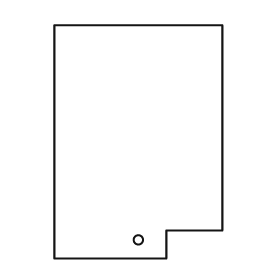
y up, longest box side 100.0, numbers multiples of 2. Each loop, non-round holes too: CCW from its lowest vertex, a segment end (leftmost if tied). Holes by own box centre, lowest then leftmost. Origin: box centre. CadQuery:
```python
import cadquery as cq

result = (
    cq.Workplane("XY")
    .moveTo(-36.0, -50.0)
    .lineTo(12.0, -50.0)
    .lineTo(12.0, -38.0)
    .lineTo(36.0, -38.0)
    .lineTo(36.0, 50.0)
    .lineTo(-36.0, 50.0)
    .close()
    .moveTo(0.0, -42.0)
    .circle(2.0)
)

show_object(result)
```